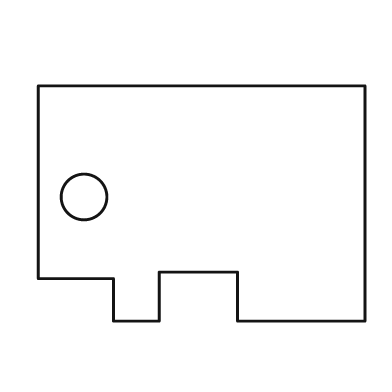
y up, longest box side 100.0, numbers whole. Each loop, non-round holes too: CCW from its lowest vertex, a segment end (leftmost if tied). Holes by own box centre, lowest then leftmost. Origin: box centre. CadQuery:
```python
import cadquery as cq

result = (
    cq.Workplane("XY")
    .moveTo(-27.0, -36.0)
    .lineTo(-13.0, -36.0)
    .lineTo(-13.0, -21.0)
    .lineTo(11.0, -21.0)
    .lineTo(11.0, -36.0)
    .lineTo(50.0, -36.0)
    .lineTo(50.0, 36.0)
    .lineTo(-50.0, 36.0)
    .lineTo(-50.0, -23.0)
    .lineTo(-27.0, -23.0)
    .close()
    .moveTo(-36.0, 2.0)
    .circle(7.0)
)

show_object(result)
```